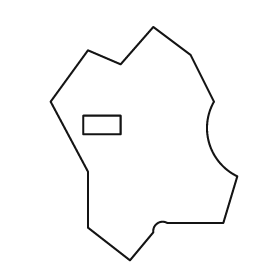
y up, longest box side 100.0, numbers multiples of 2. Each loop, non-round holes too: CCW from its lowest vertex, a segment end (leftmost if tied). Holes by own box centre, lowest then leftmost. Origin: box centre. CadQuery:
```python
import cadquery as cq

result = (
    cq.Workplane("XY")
    .moveTo(-6.0, -50.0)
    .lineTo(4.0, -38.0)
    .threePointArc((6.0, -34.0), (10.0, -34.0))
    .lineTo(34.0, -34.0)
    .lineTo(40.0, -14.0)
    .threePointArc((28.0, 0.0), (30.0, 18.0))
    .lineTo(20.0, 38.0)
    .lineTo(4.0, 50.0)
    .lineTo(-10.0, 34.0)
    .lineTo(-24.0, 40.0)
    .lineTo(-40.0, 18.0)
    .lineTo(-24.0, -12.0)
    .lineTo(-24.0, -36.0)
    .close()
    .moveTo(-26.0, 4.0)
    .lineTo(-10.0, 4.0)
    .lineTo(-10.0, 12.0)
    .lineTo(-26.0, 12.0)
    .close()
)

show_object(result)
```